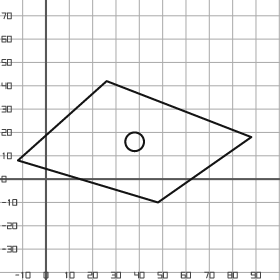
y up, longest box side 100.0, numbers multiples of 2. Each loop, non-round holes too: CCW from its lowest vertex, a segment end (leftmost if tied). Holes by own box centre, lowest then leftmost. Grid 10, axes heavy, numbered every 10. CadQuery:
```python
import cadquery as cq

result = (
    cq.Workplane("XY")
    .moveTo(48.0, -10.0)
    .lineTo(88.0, 18.0)
    .lineTo(26.0, 42.0)
    .lineTo(-12.0, 8.0)
    .close()
    .moveTo(38.0, 16.0)
    .circle(4.0)
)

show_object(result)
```